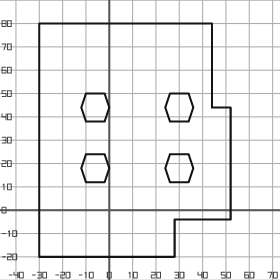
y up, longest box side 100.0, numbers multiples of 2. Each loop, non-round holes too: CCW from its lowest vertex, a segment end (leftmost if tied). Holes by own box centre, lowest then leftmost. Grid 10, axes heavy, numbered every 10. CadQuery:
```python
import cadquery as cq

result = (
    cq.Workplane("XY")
    .moveTo(-30.0, -20.0)
    .lineTo(28.0, -20.0)
    .lineTo(28.0, -4.0)
    .lineTo(52.0, -4.0)
    .lineTo(52.0, 44.0)
    .lineTo(44.0, 44.0)
    .lineTo(44.0, 80.0)
    .lineTo(-30.0, 80.0)
    .close()
    .moveTo(-10.0, 12.0)
    .lineTo(-2.0, 12.0)
    .lineTo(0.0, 18.0)
    .lineTo(-2.0, 24.0)
    .lineTo(-10.0, 24.0)
    .lineTo(-12.0, 18.0)
    .close()
    .moveTo(26.0, 12.0)
    .lineTo(34.0, 12.0)
    .lineTo(36.0, 18.0)
    .lineTo(34.0, 24.0)
    .lineTo(26.0, 24.0)
    .lineTo(24.0, 18.0)
    .close()
    .moveTo(-10.0, 38.0)
    .lineTo(-2.0, 38.0)
    .lineTo(0.0, 44.0)
    .lineTo(-2.0, 50.0)
    .lineTo(-10.0, 50.0)
    .lineTo(-12.0, 44.0)
    .close()
    .moveTo(26.0, 38.0)
    .lineTo(34.0, 38.0)
    .lineTo(36.0, 44.0)
    .lineTo(34.0, 50.0)
    .lineTo(26.0, 50.0)
    .lineTo(24.0, 44.0)
    .close()
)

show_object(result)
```